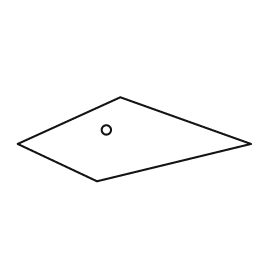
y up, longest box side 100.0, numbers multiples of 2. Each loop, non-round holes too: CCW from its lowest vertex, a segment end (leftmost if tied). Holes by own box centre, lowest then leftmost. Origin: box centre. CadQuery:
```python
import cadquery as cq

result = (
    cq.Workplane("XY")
    .moveTo(-16.0, -18.0)
    .lineTo(50.0, -2.0)
    .lineTo(-6.0, 18.0)
    .lineTo(-50.0, -2.0)
    .close()
    .moveTo(-12.0, 4.0)
    .circle(2.0)
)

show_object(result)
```